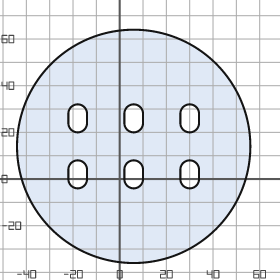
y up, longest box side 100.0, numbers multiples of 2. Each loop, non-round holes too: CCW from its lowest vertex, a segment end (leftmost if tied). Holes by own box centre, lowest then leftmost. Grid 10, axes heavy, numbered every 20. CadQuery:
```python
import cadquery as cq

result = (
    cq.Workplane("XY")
    .moveTo(6.0, 14.0)
    .circle(50.0)
    .moveTo(-22.0, 0.0)
    .threePointArc((-18.0, -4.0), (-14.0, 0.0))
    .lineTo(-14.0, 4.0)
    .threePointArc((-18.0, 8.0), (-22.0, 4.0))
    .close()
    .moveTo(2.0, 0.0)
    .threePointArc((6.0, -4.0), (10.0, 0.0))
    .lineTo(10.0, 4.0)
    .threePointArc((6.0, 8.0), (2.0, 4.0))
    .close()
    .moveTo(26.0, 0.0)
    .threePointArc((30.0, -4.0), (34.0, 0.0))
    .lineTo(34.0, 4.0)
    .threePointArc((30.0, 8.0), (26.0, 4.0))
    .close()
    .moveTo(-22.0, 24.0)
    .threePointArc((-18.0, 20.0), (-14.0, 24.0))
    .lineTo(-14.0, 28.0)
    .threePointArc((-18.0, 32.0), (-22.0, 28.0))
    .close()
    .moveTo(2.0, 24.0)
    .threePointArc((6.0, 20.0), (10.0, 24.0))
    .lineTo(10.0, 28.0)
    .threePointArc((6.0, 32.0), (2.0, 28.0))
    .close()
    .moveTo(26.0, 24.0)
    .threePointArc((30.0, 20.0), (34.0, 24.0))
    .lineTo(34.0, 28.0)
    .threePointArc((30.0, 32.0), (26.0, 28.0))
    .close()
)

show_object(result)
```